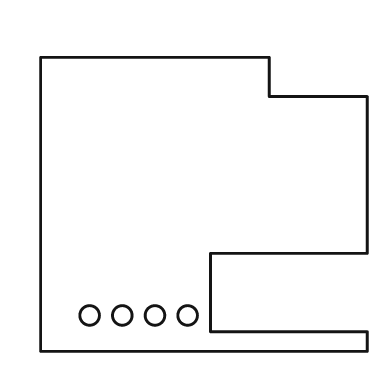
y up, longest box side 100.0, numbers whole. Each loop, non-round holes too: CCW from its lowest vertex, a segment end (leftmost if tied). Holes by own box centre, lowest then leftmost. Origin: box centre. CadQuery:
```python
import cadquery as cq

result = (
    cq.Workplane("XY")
    .moveTo(-50.0, -45.0)
    .lineTo(50.0, -45.0)
    .lineTo(50.0, -39.0)
    .lineTo(2.0, -39.0)
    .lineTo(2.0, -15.0)
    .lineTo(50.0, -15.0)
    .lineTo(50.0, 33.0)
    .lineTo(20.0, 33.0)
    .lineTo(20.0, 45.0)
    .lineTo(-50.0, 45.0)
    .close()
    .moveTo(-35.0, -34.0)
    .circle(3.0)
    .moveTo(-25.0, -34.0)
    .circle(3.0)
    .moveTo(-15.0, -34.0)
    .circle(3.0)
    .moveTo(-5.0, -34.0)
    .circle(3.0)
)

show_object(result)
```